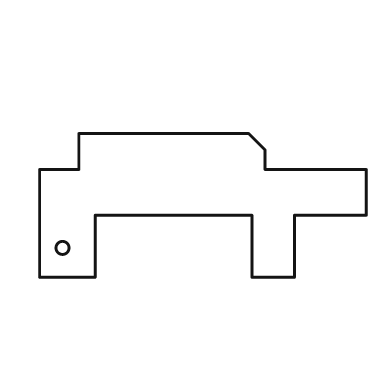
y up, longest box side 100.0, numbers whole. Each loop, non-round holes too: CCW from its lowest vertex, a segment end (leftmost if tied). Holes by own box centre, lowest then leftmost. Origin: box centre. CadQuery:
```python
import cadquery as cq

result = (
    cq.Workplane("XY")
    .moveTo(-50.0, -22.0)
    .lineTo(-33.0, -22.0)
    .lineTo(-33.0, -3.0)
    .lineTo(15.0, -3.0)
    .lineTo(15.0, -22.0)
    .lineTo(28.0, -22.0)
    .lineTo(28.0, -3.0)
    .lineTo(50.0, -3.0)
    .lineTo(50.0, 11.0)
    .lineTo(19.0, 11.0)
    .lineTo(19.0, 17.0)
    .lineTo(14.0, 22.0)
    .lineTo(-38.0, 22.0)
    .lineTo(-38.0, 11.0)
    .lineTo(-50.0, 11.0)
    .close()
    .moveTo(-43.0, -13.0)
    .circle(2.0)
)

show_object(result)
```